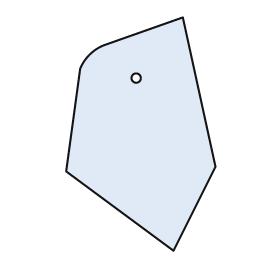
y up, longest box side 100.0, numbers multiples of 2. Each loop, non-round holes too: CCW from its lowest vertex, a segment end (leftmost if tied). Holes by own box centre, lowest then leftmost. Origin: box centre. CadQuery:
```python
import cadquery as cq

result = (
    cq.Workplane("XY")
    .moveTo(14.0, -50.0)
    .lineTo(32.0, -14.0)
    .lineTo(18.0, 50.0)
    .lineTo(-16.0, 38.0)
    .threePointArc((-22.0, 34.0), (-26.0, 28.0))
    .lineTo(-32.0, -16.0)
    .close()
    .moveTo(-2.0, 24.0)
    .circle(2.0)
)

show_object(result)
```